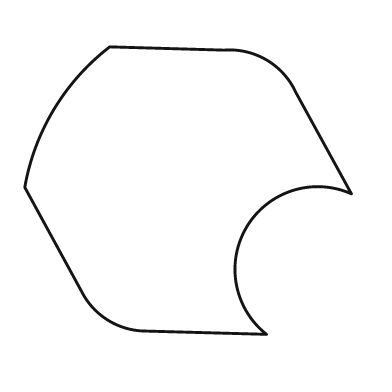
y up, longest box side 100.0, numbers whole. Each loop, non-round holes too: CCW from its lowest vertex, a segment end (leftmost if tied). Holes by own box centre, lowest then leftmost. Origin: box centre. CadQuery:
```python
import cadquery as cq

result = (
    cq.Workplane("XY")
    .moveTo(24.0, -44.0)
    .threePointArc((18.0, -11.0), (50.0, -1.0))
    .lineTo(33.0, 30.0)
    .threePointArc((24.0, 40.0), (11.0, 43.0))
    .lineTo(-24.0, 44.0)
    .threePointArc((-41.0, 25.0), (-50.0, 1.0))
    .lineTo(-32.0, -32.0)
    .threePointArc((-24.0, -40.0), (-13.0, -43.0))
    .close()
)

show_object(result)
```